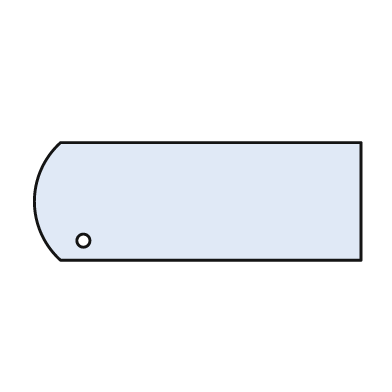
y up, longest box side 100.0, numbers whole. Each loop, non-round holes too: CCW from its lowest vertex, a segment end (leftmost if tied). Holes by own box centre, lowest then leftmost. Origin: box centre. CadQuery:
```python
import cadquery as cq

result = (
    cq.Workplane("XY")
    .moveTo(-42.0, -18.0)
    .lineTo(50.0, -18.0)
    .lineTo(50.0, 18.0)
    .lineTo(-42.0, 18.0)
    .threePointArc((-50.0, 0.0), (-42.0, -18.0))
    .close()
    .moveTo(-35.0, -12.0)
    .circle(2.0)
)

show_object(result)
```